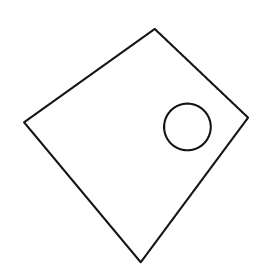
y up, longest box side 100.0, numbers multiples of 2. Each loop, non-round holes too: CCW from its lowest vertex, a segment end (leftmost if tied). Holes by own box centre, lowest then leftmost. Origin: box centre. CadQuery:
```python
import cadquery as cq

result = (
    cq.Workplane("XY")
    .moveTo(2.0, -50.0)
    .lineTo(48.0, 12.0)
    .lineTo(8.0, 50.0)
    .lineTo(-48.0, 10.0)
    .close()
    .moveTo(22.0, 8.0)
    .circle(10.0)
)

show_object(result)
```